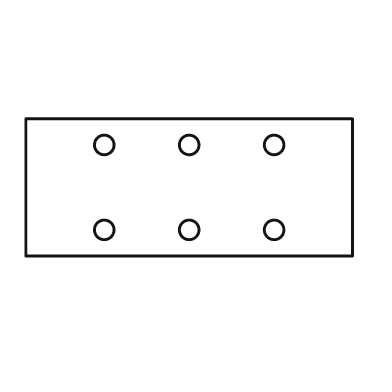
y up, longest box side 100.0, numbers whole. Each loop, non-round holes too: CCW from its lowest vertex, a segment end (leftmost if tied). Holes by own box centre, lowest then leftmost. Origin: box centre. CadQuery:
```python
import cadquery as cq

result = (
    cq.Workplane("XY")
    .moveTo(-50.0, -21.0)
    .lineTo(50.0, -21.0)
    .lineTo(50.0, 21.0)
    .lineTo(-50.0, 21.0)
    .close()
    .moveTo(-26.0, -13.0)
    .circle(3.0)
    .moveTo(0.0, -13.0)
    .circle(3.0)
    .moveTo(26.0, -13.0)
    .circle(3.0)
    .moveTo(-26.0, 13.0)
    .circle(3.0)
    .moveTo(0.0, 13.0)
    .circle(3.0)
    .moveTo(26.0, 13.0)
    .circle(3.0)
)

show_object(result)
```